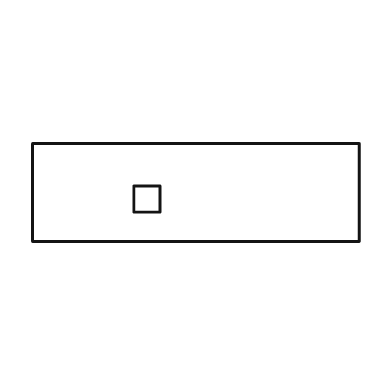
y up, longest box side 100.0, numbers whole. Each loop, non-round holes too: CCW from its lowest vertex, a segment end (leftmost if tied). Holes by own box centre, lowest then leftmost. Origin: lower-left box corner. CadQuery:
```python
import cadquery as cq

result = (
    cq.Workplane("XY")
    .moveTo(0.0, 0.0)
    .lineTo(100.0, 0.0)
    .lineTo(100.0, 30.0)
    .lineTo(0.0, 30.0)
    .close()
    .moveTo(31.0, 9.0)
    .lineTo(39.0, 9.0)
    .lineTo(39.0, 17.0)
    .lineTo(31.0, 17.0)
    .close()
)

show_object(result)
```